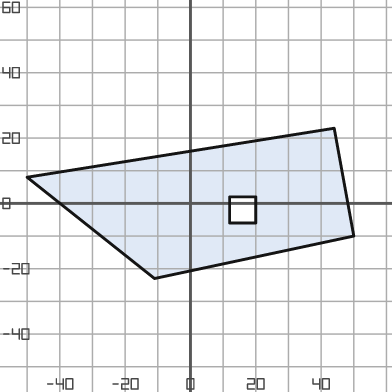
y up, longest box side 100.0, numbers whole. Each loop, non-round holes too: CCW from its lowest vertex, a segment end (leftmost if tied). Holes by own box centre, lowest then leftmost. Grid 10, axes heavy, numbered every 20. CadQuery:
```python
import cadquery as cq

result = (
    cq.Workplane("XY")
    .moveTo(-11.0, -23.0)
    .lineTo(50.0, -10.0)
    .lineTo(44.0, 23.0)
    .lineTo(-50.0, 8.0)
    .close()
    .moveTo(12.0, -6.0)
    .lineTo(20.0, -6.0)
    .lineTo(20.0, 2.0)
    .lineTo(12.0, 2.0)
    .close()
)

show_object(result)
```